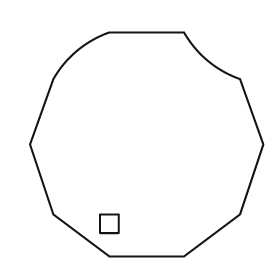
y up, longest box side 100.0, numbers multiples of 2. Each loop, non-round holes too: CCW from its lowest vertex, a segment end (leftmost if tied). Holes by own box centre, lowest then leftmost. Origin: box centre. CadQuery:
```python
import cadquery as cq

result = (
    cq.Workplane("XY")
    .moveTo(-16.0, -48.0)
    .lineTo(16.0, -48.0)
    .lineTo(40.0, -30.0)
    .lineTo(50.0, 0.0)
    .lineTo(40.0, 28.0)
    .threePointArc((26.0, 36.0), (16.0, 48.0))
    .lineTo(-16.0, 48.0)
    .threePointArc((-30.0, 40.0), (-40.0, 28.0))
    .lineTo(-50.0, 0.0)
    .lineTo(-40.0, -30.0)
    .close()
    .moveTo(-20.0, -38.0)
    .lineTo(-12.0, -38.0)
    .lineTo(-12.0, -30.0)
    .lineTo(-20.0, -30.0)
    .close()
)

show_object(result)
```